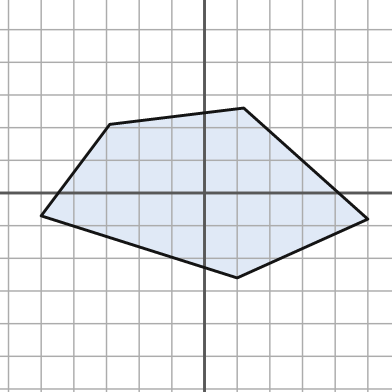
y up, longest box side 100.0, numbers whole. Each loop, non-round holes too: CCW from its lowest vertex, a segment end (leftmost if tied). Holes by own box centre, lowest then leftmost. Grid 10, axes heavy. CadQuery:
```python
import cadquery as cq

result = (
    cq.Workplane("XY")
    .moveTo(10.0, -26.0)
    .lineTo(50.0, -8.0)
    .lineTo(12.0, 26.0)
    .lineTo(-29.0, 21.0)
    .lineTo(-50.0, -7.0)
    .close()
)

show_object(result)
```